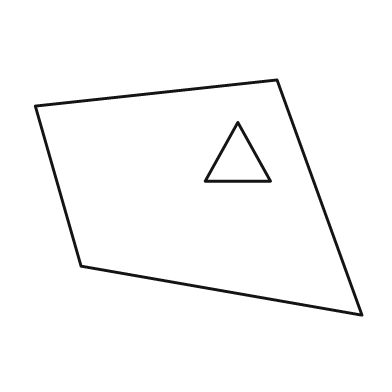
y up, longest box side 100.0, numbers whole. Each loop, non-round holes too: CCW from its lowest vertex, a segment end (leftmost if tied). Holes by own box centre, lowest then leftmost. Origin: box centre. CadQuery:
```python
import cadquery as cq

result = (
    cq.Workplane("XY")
    .moveTo(50.0, -36.0)
    .lineTo(24.0, 36.0)
    .lineTo(-50.0, 28.0)
    .lineTo(-36.0, -21.0)
    .close()
    .moveTo(2.0, 5.0)
    .lineTo(22.0, 5.0)
    .lineTo(12.0, 23.0)
    .close()
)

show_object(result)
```